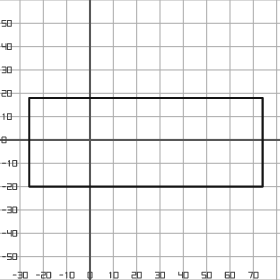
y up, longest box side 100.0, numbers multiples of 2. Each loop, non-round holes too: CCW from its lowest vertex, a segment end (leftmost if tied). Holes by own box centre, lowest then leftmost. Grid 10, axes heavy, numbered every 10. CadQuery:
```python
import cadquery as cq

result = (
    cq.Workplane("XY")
    .moveTo(-26.0, -20.0)
    .lineTo(74.0, -20.0)
    .lineTo(74.0, 18.0)
    .lineTo(-26.0, 18.0)
    .close()
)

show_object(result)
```